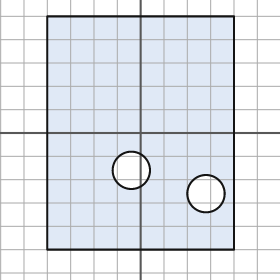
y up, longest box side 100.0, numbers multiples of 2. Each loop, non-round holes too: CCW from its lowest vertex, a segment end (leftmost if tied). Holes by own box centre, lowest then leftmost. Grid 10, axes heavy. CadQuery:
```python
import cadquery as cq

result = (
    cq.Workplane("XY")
    .moveTo(-40.0, -50.0)
    .lineTo(40.0, -50.0)
    .lineTo(40.0, 50.0)
    .lineTo(-40.0, 50.0)
    .close()
    .moveTo(28.0, -26.0)
    .circle(8.0)
    .moveTo(-4.0, -16.0)
    .circle(8.0)
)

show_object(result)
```